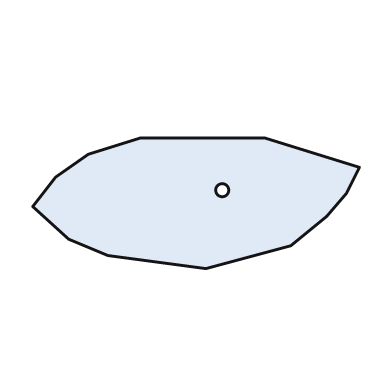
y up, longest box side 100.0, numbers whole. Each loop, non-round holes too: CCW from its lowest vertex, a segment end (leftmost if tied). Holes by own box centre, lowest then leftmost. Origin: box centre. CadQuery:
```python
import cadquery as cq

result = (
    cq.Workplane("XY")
    .moveTo(3.0, -20.0)
    .lineTo(29.0, -13.0)
    .lineTo(40.0, -4.0)
    .lineTo(46.0, 3.0)
    .lineTo(50.0, 11.0)
    .lineTo(21.0, 20.0)
    .lineTo(-17.0, 20.0)
    .lineTo(-33.0, 15.0)
    .lineTo(-43.0, 8.0)
    .lineTo(-50.0, -1.0)
    .lineTo(-39.0, -11.0)
    .lineTo(-27.0, -16.0)
    .close()
    .moveTo(8.0, 4.0)
    .circle(2.0)
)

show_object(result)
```